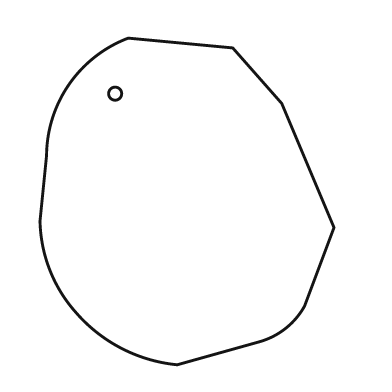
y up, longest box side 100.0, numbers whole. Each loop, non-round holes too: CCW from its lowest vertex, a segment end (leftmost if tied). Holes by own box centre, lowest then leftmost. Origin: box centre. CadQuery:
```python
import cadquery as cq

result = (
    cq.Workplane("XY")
    .moveTo(-3.0, -50.0)
    .lineTo(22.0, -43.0)
    .threePointArc((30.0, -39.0), (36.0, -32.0))
    .lineTo(45.0, -8.0)
    .lineTo(29.0, 30.0)
    .lineTo(14.0, 47.0)
    .lineTo(-18.0, 50.0)
    .threePointArc((-36.0, 36.0), (-43.0, 14.0))
    .lineTo(-45.0, -6.0)
    .threePointArc((-42.0, -21.0), (-34.0, -34.0))
    .threePointArc((-20.0, -45.0), (-3.0, -50.0))
    .close()
    .moveTo(-22.0, 33.0)
    .circle(2.0)
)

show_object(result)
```